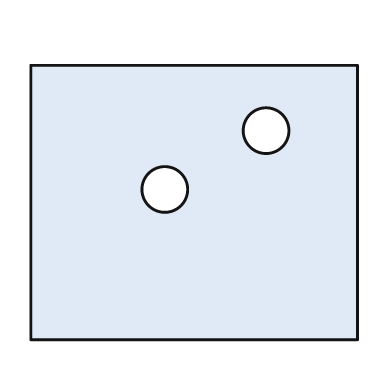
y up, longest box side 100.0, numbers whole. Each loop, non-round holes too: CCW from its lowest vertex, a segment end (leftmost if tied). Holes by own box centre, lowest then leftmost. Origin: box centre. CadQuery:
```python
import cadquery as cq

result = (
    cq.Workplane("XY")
    .moveTo(-50.0, -42.0)
    .lineTo(50.0, -42.0)
    .lineTo(50.0, 42.0)
    .lineTo(-50.0, 42.0)
    .close()
    .moveTo(-9.0, 4.0)
    .circle(7.0)
    .moveTo(22.0, 22.0)
    .circle(7.0)
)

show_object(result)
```